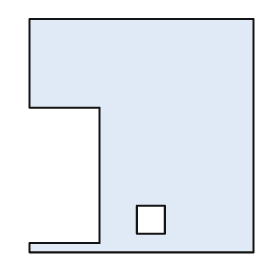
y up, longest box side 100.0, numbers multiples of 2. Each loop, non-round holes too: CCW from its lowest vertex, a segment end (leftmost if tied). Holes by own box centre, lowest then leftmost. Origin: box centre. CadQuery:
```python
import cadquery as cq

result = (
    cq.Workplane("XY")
    .moveTo(-48.0, -50.0)
    .lineTo(48.0, -50.0)
    .lineTo(48.0, 50.0)
    .lineTo(-48.0, 50.0)
    .lineTo(-48.0, 12.0)
    .lineTo(-18.0, 12.0)
    .lineTo(-18.0, -46.0)
    .lineTo(-48.0, -46.0)
    .close()
    .moveTo(-2.0, -42.0)
    .lineTo(10.0, -42.0)
    .lineTo(10.0, -30.0)
    .lineTo(-2.0, -30.0)
    .close()
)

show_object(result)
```